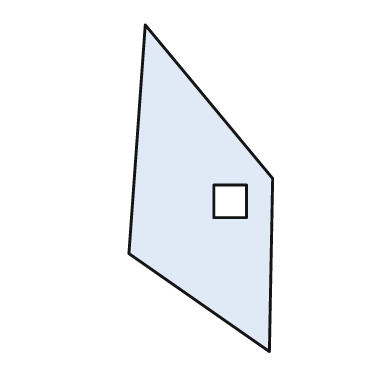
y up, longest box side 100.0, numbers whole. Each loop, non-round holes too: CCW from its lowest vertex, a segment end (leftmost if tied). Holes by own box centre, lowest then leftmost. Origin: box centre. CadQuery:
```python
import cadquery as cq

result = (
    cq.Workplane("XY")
    .moveTo(21.0, -50.0)
    .lineTo(22.0, 3.0)
    .lineTo(-17.0, 50.0)
    .lineTo(-22.0, -20.0)
    .close()
    .moveTo(4.0, -9.0)
    .lineTo(14.0, -9.0)
    .lineTo(14.0, 1.0)
    .lineTo(4.0, 1.0)
    .close()
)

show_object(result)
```